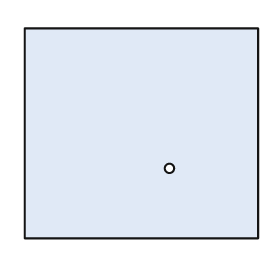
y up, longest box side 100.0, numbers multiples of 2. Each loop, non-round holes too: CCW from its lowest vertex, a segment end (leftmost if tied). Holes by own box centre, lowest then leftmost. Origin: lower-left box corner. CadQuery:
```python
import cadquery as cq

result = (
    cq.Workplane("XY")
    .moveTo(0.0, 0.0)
    .lineTo(100.0, 0.0)
    .lineTo(100.0, 90.0)
    .lineTo(0.0, 90.0)
    .close()
    .moveTo(62.0, 30.0)
    .circle(2.0)
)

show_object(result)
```